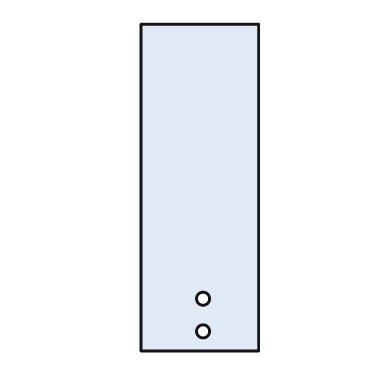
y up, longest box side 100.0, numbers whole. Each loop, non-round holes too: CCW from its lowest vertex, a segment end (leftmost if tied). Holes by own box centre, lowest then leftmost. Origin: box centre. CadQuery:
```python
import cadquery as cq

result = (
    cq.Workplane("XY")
    .moveTo(-18.0, -50.0)
    .lineTo(18.0, -50.0)
    .lineTo(18.0, 50.0)
    .lineTo(-18.0, 50.0)
    .close()
    .moveTo(1.0, -44.0)
    .circle(2.0)
    .moveTo(1.0, -34.0)
    .circle(2.0)
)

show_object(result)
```